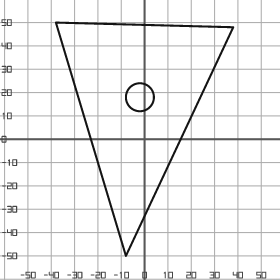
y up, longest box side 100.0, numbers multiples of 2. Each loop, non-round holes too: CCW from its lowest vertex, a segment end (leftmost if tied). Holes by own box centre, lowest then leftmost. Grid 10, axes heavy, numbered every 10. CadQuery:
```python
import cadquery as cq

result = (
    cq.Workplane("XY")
    .moveTo(-8.0, -50.0)
    .lineTo(38.0, 48.0)
    .lineTo(-38.0, 50.0)
    .close()
    .moveTo(-2.0, 18.0)
    .circle(6.0)
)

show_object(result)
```